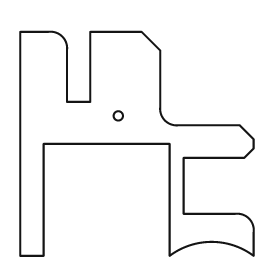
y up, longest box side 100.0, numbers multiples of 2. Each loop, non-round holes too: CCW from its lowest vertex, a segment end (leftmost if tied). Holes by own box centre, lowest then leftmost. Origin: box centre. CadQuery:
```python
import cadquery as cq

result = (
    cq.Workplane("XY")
    .moveTo(-50.0, -48.0)
    .lineTo(-40.0, -48.0)
    .lineTo(-40.0, 0.0)
    .lineTo(14.0, 0.0)
    .lineTo(14.0, -48.0)
    .threePointArc((32.0, -42.0), (50.0, -48.0))
    .lineTo(50.0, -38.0)
    .threePointArc((48.0, -32.0), (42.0, -30.0))
    .lineTo(20.0, -30.0)
    .lineTo(20.0, -6.0)
    .lineTo(46.0, -6.0)
    .lineTo(50.0, -2.0)
    .lineTo(50.0, 2.0)
    .lineTo(44.0, 8.0)
    .lineTo(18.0, 8.0)
    .threePointArc((12.0, 10.0), (10.0, 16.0))
    .lineTo(10.0, 40.0)
    .lineTo(2.0, 48.0)
    .lineTo(-20.0, 48.0)
    .lineTo(-20.0, 18.0)
    .lineTo(-30.0, 18.0)
    .lineTo(-30.0, 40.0)
    .threePointArc((-32.0, 46.0), (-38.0, 48.0))
    .lineTo(-50.0, 48.0)
    .close()
    .moveTo(-8.0, 12.0)
    .circle(2.0)
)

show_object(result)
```